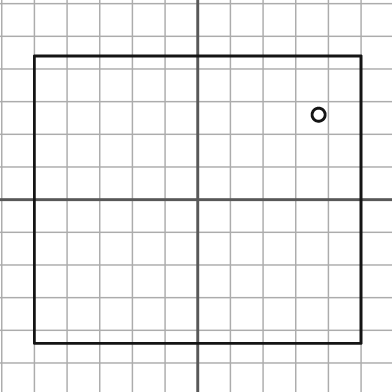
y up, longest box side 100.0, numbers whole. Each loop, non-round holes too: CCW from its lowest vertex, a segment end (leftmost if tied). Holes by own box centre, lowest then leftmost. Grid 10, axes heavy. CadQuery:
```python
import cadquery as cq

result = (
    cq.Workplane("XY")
    .moveTo(-50.0, -44.0)
    .lineTo(50.0, -44.0)
    .lineTo(50.0, 44.0)
    .lineTo(-50.0, 44.0)
    .close()
    .moveTo(37.0, 26.0)
    .circle(2.0)
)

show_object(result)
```